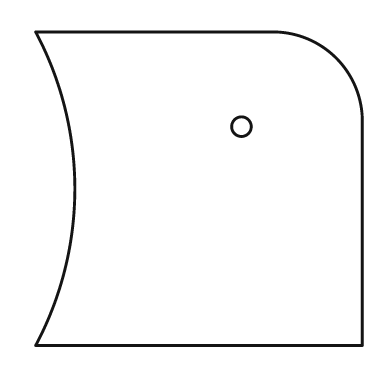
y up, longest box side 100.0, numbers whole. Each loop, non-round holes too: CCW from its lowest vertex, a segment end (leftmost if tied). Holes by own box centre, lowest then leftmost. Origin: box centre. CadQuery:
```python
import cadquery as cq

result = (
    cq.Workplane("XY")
    .moveTo(-50.0, -48.0)
    .lineTo(50.0, -48.0)
    .lineTo(50.0, 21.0)
    .threePointArc((42.0, 40.0), (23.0, 48.0))
    .lineTo(-50.0, 48.0)
    .threePointArc((-38.0, 0.0), (-50.0, -48.0))
    .close()
    .moveTo(13.0, 19.0)
    .circle(3.0)
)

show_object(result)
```